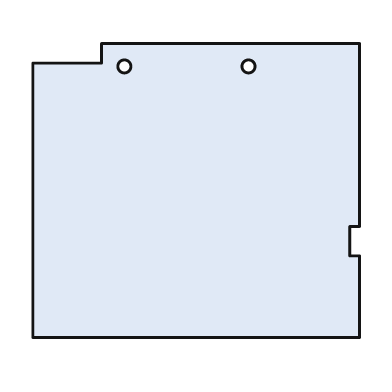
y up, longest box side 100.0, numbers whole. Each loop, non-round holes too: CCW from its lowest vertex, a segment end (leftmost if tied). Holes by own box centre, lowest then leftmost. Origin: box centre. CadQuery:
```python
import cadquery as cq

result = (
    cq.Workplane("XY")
    .moveTo(-50.0, -45.0)
    .lineTo(50.0, -45.0)
    .lineTo(50.0, -20.0)
    .lineTo(47.0, -20.0)
    .lineTo(47.0, -11.0)
    .lineTo(50.0, -11.0)
    .lineTo(50.0, 45.0)
    .lineTo(-29.0, 45.0)
    .lineTo(-29.0, 39.0)
    .lineTo(-50.0, 39.0)
    .close()
    .moveTo(-22.0, 38.0)
    .circle(2.0)
    .moveTo(16.0, 38.0)
    .circle(2.0)
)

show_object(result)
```